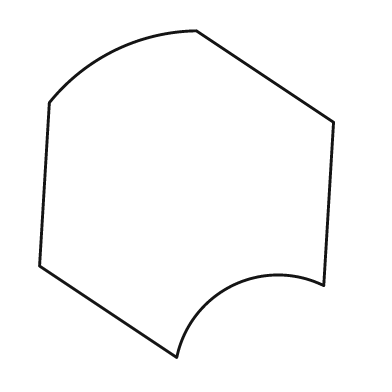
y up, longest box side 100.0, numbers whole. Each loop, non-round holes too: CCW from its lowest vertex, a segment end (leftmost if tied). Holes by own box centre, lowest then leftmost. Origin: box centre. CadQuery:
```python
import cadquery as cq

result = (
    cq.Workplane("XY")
    .moveTo(-3.0, -50.0)
    .threePointArc((14.0, -28.0), (42.0, -28.0))
    .lineTo(45.0, 22.0)
    .lineTo(3.0, 50.0)
    .threePointArc((-22.0, 44.0), (-42.0, 28.0))
    .lineTo(-45.0, -22.0)
    .close()
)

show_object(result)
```